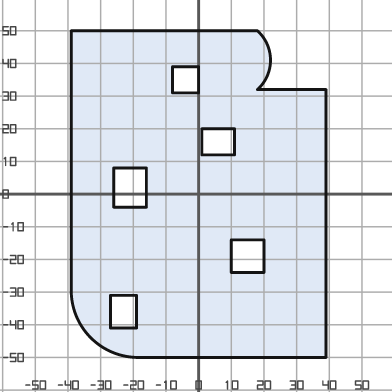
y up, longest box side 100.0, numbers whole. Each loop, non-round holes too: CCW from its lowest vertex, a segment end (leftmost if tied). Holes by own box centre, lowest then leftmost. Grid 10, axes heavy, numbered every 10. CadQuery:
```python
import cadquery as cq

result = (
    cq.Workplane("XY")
    .moveTo(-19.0, -50.0)
    .lineTo(39.0, -50.0)
    .lineTo(39.0, 32.0)
    .lineTo(18.0, 32.0)
    .threePointArc((22.0, 41.0), (18.0, 50.0))
    .lineTo(-39.0, 50.0)
    .lineTo(-39.0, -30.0)
    .threePointArc((-33.0, -44.0), (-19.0, -50.0))
    .close()
    .moveTo(-27.0, -41.0)
    .lineTo(-19.0, -41.0)
    .lineTo(-19.0, -31.0)
    .lineTo(-27.0, -31.0)
    .close()
    .moveTo(10.0, -24.0)
    .lineTo(20.0, -24.0)
    .lineTo(20.0, -14.0)
    .lineTo(10.0, -14.0)
    .close()
    .moveTo(-26.0, -4.0)
    .lineTo(-16.0, -4.0)
    .lineTo(-16.0, 8.0)
    .lineTo(-26.0, 8.0)
    .close()
    .moveTo(1.0, 12.0)
    .lineTo(11.0, 12.0)
    .lineTo(11.0, 20.0)
    .lineTo(1.0, 20.0)
    .close()
    .moveTo(-8.0, 31.0)
    .lineTo(0.0, 31.0)
    .lineTo(0.0, 39.0)
    .lineTo(-8.0, 39.0)
    .close()
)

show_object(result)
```